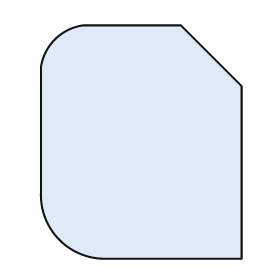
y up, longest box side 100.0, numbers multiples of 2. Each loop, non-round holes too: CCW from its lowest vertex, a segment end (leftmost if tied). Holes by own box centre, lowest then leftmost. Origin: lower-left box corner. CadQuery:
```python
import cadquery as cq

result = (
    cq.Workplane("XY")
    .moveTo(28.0, 0.0)
    .lineTo(86.0, 0.0)
    .lineTo(86.0, 74.0)
    .lineTo(60.0, 100.0)
    .lineTo(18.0, 100.0)
    .threePointArc((6.0, 94.0), (0.0, 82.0))
    .lineTo(0.0, 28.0)
    .threePointArc((8.0, 8.0), (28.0, 0.0))
    .close()
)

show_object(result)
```